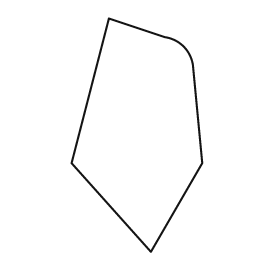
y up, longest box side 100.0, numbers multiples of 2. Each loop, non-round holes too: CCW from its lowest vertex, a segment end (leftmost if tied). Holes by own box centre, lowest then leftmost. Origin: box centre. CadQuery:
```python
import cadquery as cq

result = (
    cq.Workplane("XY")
    .moveTo(6.0, -50.0)
    .lineTo(28.0, -12.0)
    .lineTo(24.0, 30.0)
    .threePointArc((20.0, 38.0), (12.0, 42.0))
    .lineTo(-12.0, 50.0)
    .lineTo(-28.0, -12.0)
    .close()
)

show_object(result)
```